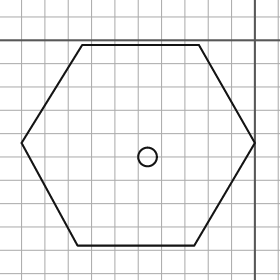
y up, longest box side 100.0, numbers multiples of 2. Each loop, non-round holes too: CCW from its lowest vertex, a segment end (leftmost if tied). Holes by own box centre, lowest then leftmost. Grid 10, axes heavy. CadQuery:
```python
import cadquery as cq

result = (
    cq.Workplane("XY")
    .moveTo(-76.0, -88.0)
    .lineTo(-26.0, -88.0)
    .lineTo(0.0, -44.0)
    .lineTo(-24.0, -2.0)
    .lineTo(-74.0, -2.0)
    .lineTo(-100.0, -44.0)
    .close()
    .moveTo(-46.0, -50.0)
    .circle(4.0)
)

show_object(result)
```